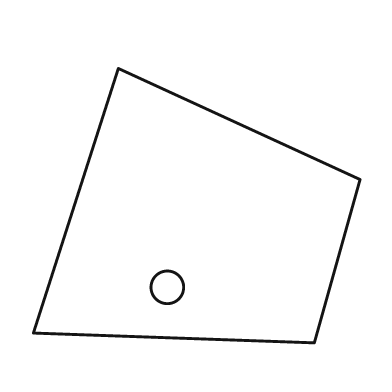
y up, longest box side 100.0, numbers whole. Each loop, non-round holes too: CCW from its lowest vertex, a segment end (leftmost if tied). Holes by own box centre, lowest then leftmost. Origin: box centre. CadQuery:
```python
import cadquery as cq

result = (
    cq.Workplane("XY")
    .moveTo(36.0, -42.0)
    .lineTo(50.0, 8.0)
    .lineTo(-24.0, 42.0)
    .lineTo(-50.0, -39.0)
    .close()
    .moveTo(-9.0, -25.0)
    .circle(5.0)
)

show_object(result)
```